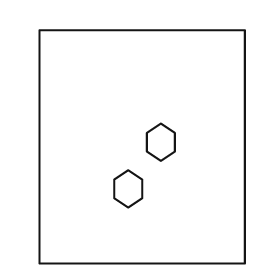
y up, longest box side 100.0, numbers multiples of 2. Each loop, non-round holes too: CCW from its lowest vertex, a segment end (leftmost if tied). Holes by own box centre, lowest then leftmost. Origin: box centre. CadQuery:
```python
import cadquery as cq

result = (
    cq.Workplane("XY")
    .moveTo(-44.0, -50.0)
    .lineTo(44.0, -50.0)
    .lineTo(44.0, 50.0)
    .lineTo(-44.0, 50.0)
    .close()
    .moveTo(-6.0, -26.0)
    .lineTo(0.0, -22.0)
    .lineTo(0.0, -14.0)
    .lineTo(-6.0, -10.0)
    .lineTo(-12.0, -14.0)
    .lineTo(-12.0, -22.0)
    .close()
    .moveTo(8.0, -6.0)
    .lineTo(14.0, -2.0)
    .lineTo(14.0, 6.0)
    .lineTo(8.0, 10.0)
    .lineTo(2.0, 6.0)
    .lineTo(2.0, -2.0)
    .close()
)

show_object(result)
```